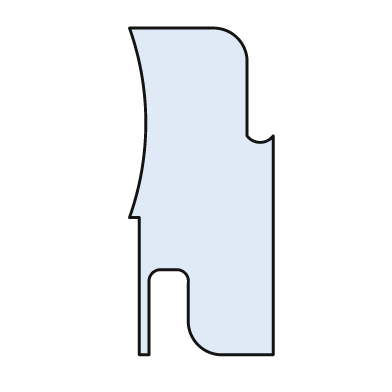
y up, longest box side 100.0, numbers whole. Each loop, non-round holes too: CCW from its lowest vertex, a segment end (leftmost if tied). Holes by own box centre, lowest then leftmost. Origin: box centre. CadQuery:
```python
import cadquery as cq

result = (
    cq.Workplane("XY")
    .moveTo(-19.0, -50.0)
    .lineTo(-16.0, -50.0)
    .lineTo(-16.0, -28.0)
    .threePointArc((-15.0, -25.0), (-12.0, -24.0))
    .lineTo(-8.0, -24.0)
    .threePointArc((-5.0, -25.0), (-4.0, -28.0))
    .lineTo(-4.0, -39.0)
    .threePointArc((-1.0, -47.0), (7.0, -50.0))
    .lineTo(22.0, -50.0)
    .lineTo(22.0, 17.0)
    .threePointArc((18.0, 15.0), (14.0, 17.0))
    .lineTo(14.0, 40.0)
    .threePointArc((11.0, 47.0), (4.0, 50.0))
    .lineTo(-22.0, 50.0)
    .threePointArc((-17.0, 21.0), (-22.0, -8.0))
    .lineTo(-19.0, -8.0)
    .close()
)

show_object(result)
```